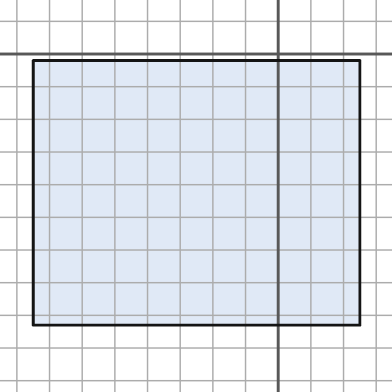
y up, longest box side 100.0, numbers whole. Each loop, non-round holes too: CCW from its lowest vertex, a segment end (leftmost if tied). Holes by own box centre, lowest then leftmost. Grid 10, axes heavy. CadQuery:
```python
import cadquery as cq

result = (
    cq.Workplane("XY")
    .moveTo(-75.0, -83.0)
    .lineTo(25.0, -83.0)
    .lineTo(25.0, -2.0)
    .lineTo(-75.0, -2.0)
    .close()
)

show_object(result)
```